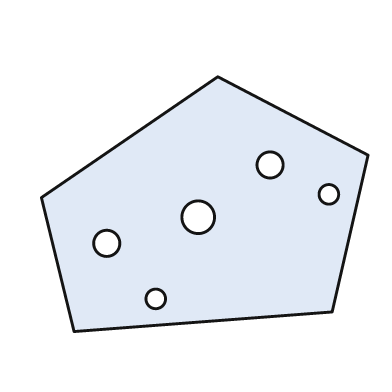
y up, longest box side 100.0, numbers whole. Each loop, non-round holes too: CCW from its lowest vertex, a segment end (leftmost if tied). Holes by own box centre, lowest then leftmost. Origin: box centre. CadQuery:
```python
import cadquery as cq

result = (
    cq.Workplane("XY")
    .moveTo(-40.0, -39.0)
    .lineTo(39.0, -33.0)
    .lineTo(50.0, 15.0)
    .lineTo(4.0, 39.0)
    .lineTo(-50.0, 2.0)
    .close()
    .moveTo(-15.0, -29.0)
    .circle(3.0)
    .moveTo(-30.0, -12.0)
    .circle(4.0)
    .moveTo(-2.0, -4.0)
    .circle(5.0)
    .moveTo(38.0, 3.0)
    .circle(3.0)
    .moveTo(20.0, 12.0)
    .circle(4.0)
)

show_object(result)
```